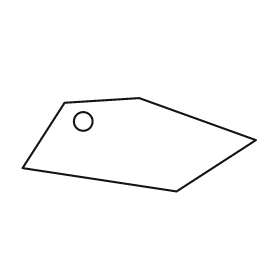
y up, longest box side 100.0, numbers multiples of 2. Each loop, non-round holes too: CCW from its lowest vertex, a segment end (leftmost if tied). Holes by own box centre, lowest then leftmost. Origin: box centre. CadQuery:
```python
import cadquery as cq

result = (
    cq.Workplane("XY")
    .moveTo(16.0, -20.0)
    .lineTo(50.0, 2.0)
    .lineTo(0.0, 20.0)
    .lineTo(-32.0, 18.0)
    .lineTo(-50.0, -10.0)
    .close()
    .moveTo(-24.0, 10.0)
    .circle(4.0)
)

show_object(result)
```